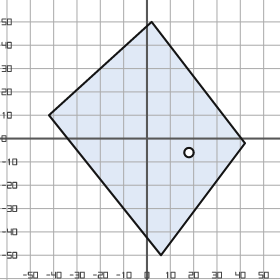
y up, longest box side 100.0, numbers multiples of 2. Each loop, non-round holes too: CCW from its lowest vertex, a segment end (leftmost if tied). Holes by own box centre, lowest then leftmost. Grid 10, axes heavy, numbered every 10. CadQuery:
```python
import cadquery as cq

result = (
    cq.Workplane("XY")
    .moveTo(6.0, -50.0)
    .lineTo(42.0, -2.0)
    .lineTo(2.0, 50.0)
    .lineTo(-42.0, 10.0)
    .close()
    .moveTo(18.0, -6.0)
    .circle(2.0)
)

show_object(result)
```